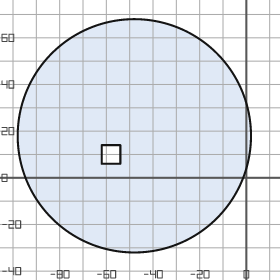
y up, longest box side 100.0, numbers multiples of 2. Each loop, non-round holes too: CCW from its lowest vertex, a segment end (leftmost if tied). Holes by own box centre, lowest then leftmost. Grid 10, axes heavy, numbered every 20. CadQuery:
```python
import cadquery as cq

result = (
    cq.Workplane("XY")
    .moveTo(-48.0, 18.0)
    .circle(50.0)
    .moveTo(-62.0, 6.0)
    .lineTo(-54.0, 6.0)
    .lineTo(-54.0, 14.0)
    .lineTo(-62.0, 14.0)
    .close()
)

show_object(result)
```